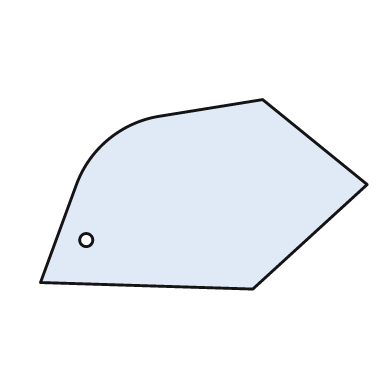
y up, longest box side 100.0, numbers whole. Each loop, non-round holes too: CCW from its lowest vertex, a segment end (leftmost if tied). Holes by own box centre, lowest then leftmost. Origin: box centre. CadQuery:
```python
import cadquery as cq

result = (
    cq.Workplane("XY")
    .moveTo(15.0, -29.0)
    .lineTo(50.0, 3.0)
    .lineTo(18.0, 29.0)
    .lineTo(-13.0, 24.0)
    .threePointArc((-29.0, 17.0), (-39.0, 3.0))
    .lineTo(-50.0, -27.0)
    .close()
    .moveTo(-36.0, -14.0)
    .circle(2.0)
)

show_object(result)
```